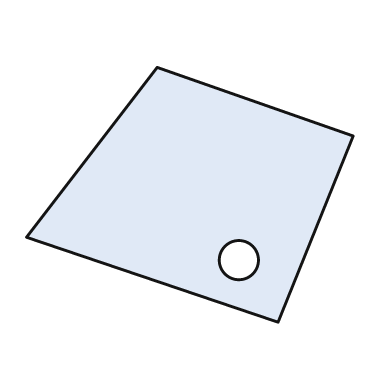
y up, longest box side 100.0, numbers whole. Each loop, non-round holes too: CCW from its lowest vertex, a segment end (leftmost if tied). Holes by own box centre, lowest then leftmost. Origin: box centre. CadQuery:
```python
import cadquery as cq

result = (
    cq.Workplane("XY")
    .moveTo(27.0, -39.0)
    .lineTo(50.0, 18.0)
    .lineTo(-10.0, 39.0)
    .lineTo(-50.0, -13.0)
    .close()
    .moveTo(15.0, -20.0)
    .circle(6.0)
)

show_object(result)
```